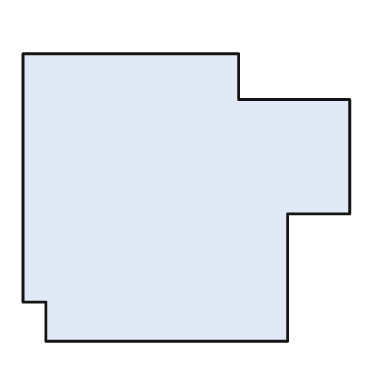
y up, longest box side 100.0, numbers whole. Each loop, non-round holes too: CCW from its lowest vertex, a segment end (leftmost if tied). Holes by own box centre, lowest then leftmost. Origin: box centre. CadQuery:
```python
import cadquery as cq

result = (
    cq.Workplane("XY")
    .moveTo(-43.0, -44.0)
    .lineTo(31.0, -44.0)
    .lineTo(31.0, -5.0)
    .lineTo(50.0, -5.0)
    .lineTo(50.0, 30.0)
    .lineTo(16.0, 30.0)
    .lineTo(16.0, 44.0)
    .lineTo(-50.0, 44.0)
    .lineTo(-50.0, -32.0)
    .lineTo(-43.0, -32.0)
    .close()
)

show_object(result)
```